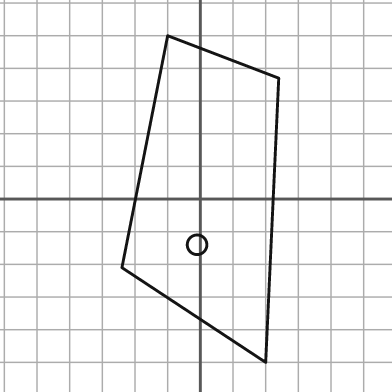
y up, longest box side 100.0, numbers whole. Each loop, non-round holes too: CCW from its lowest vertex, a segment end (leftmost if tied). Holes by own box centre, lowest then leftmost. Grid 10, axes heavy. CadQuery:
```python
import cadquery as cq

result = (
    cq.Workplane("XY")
    .moveTo(20.0, -50.0)
    .lineTo(24.0, 37.0)
    .lineTo(-10.0, 50.0)
    .lineTo(-24.0, -21.0)
    .close()
    .moveTo(-1.0, -14.0)
    .circle(3.0)
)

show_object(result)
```